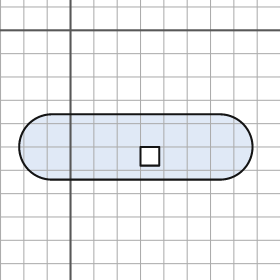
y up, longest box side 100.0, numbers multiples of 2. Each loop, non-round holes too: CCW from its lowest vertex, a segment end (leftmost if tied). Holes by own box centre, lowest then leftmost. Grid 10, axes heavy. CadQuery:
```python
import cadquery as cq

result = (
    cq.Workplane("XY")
    .moveTo(-8.0, -64.0)
    .lineTo(64.0, -64.0)
    .threePointArc((78.0, -50.0), (64.0, -36.0))
    .lineTo(-8.0, -36.0)
    .threePointArc((-22.0, -50.0), (-8.0, -64.0))
    .close()
    .moveTo(30.0, -58.0)
    .lineTo(38.0, -58.0)
    .lineTo(38.0, -50.0)
    .lineTo(30.0, -50.0)
    .close()
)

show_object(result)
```